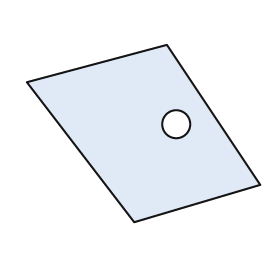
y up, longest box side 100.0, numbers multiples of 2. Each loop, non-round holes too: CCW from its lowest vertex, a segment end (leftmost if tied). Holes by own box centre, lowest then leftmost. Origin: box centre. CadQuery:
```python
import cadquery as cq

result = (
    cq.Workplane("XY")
    .moveTo(-4.0, -38.0)
    .lineTo(50.0, -22.0)
    .lineTo(10.0, 38.0)
    .lineTo(-50.0, 22.0)
    .close()
    .moveTo(14.0, 4.0)
    .circle(6.0)
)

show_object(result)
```